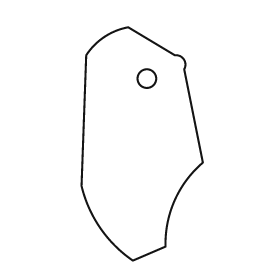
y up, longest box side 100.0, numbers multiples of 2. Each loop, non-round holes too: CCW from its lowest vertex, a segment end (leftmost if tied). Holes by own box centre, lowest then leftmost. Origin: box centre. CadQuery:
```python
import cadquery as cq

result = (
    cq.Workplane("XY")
    .moveTo(-4.0, -50.0)
    .lineTo(10.0, -44.0)
    .threePointArc((14.0, -24.0), (26.0, -8.0))
    .lineTo(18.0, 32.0)
    .threePointArc((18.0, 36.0), (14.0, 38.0))
    .lineTo(-6.0, 50.0)
    .threePointArc((-16.0, 46.0), (-24.0, 38.0))
    .lineTo(-26.0, -18.0)
    .threePointArc((-18.0, -36.0), (-4.0, -50.0))
    .close()
    .moveTo(2.0, 28.0)
    .circle(4.0)
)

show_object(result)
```